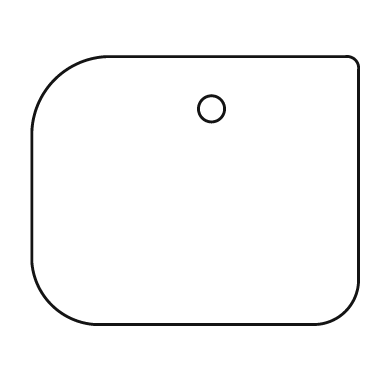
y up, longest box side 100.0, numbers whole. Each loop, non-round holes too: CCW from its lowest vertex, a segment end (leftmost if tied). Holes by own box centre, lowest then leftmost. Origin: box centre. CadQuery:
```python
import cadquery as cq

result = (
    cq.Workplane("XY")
    .moveTo(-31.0, -41.0)
    .lineTo(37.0, -41.0)
    .threePointArc((46.0, -37.0), (50.0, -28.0))
    .lineTo(50.0, 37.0)
    .threePointArc((49.0, 40.0), (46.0, 41.0))
    .lineTo(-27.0, 41.0)
    .threePointArc((-43.0, 34.0), (-50.0, 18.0))
    .lineTo(-50.0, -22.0)
    .threePointArc((-44.0, -35.0), (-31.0, -41.0))
    .close()
    .moveTo(5.0, 25.0)
    .circle(4.0)
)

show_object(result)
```